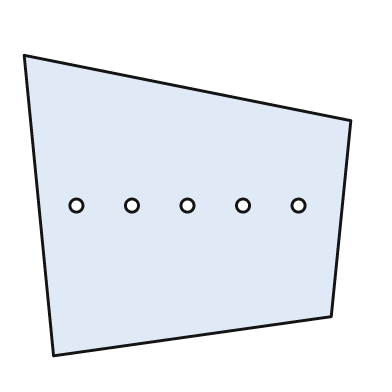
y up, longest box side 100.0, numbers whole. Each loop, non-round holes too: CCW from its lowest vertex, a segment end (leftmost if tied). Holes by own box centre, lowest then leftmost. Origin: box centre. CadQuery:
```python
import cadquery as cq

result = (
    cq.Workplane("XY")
    .moveTo(-41.0, -46.0)
    .lineTo(44.0, -34.0)
    .lineTo(50.0, 26.0)
    .lineTo(-50.0, 46.0)
    .close()
    .moveTo(-34.0, 0.0)
    .circle(2.0)
    .moveTo(-17.0, 0.0)
    .circle(2.0)
    .moveTo(0.0, 0.0)
    .circle(2.0)
    .moveTo(17.0, 0.0)
    .circle(2.0)
    .moveTo(34.0, 0.0)
    .circle(2.0)
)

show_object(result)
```